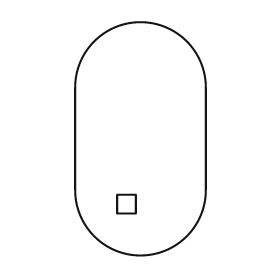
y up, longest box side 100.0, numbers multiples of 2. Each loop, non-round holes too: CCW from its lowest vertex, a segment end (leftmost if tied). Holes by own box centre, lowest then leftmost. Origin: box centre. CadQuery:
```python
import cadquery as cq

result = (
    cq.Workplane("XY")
    .moveTo(-28.0, -22.0)
    .threePointArc((0.0, -50.0), (28.0, -22.0))
    .lineTo(28.0, 22.0)
    .threePointArc((0.0, 50.0), (-28.0, 22.0))
    .close()
    .moveTo(-10.0, -32.0)
    .lineTo(-2.0, -32.0)
    .lineTo(-2.0, -24.0)
    .lineTo(-10.0, -24.0)
    .close()
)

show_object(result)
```